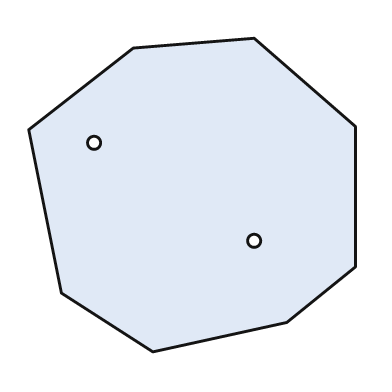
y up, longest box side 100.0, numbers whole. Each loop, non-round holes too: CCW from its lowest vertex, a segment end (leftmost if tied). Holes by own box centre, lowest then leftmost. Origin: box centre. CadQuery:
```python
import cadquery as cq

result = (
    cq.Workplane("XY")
    .moveTo(-12.0, -48.0)
    .lineTo(29.0, -39.0)
    .lineTo(50.0, -22.0)
    .lineTo(50.0, 21.0)
    .lineTo(19.0, 48.0)
    .lineTo(-18.0, 45.0)
    .lineTo(-50.0, 20.0)
    .lineTo(-40.0, -30.0)
    .close()
    .moveTo(19.0, -14.0)
    .circle(2.0)
    .moveTo(-30.0, 16.0)
    .circle(2.0)
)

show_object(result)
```